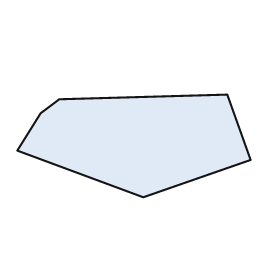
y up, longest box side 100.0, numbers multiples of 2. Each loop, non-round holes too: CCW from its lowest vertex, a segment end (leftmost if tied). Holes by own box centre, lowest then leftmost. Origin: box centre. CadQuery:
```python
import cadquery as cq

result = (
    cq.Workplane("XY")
    .moveTo(4.0, -22.0)
    .lineTo(50.0, -6.0)
    .lineTo(40.0, 22.0)
    .lineTo(-32.0, 20.0)
    .lineTo(-40.0, 14.0)
    .lineTo(-50.0, -2.0)
    .close()
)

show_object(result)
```